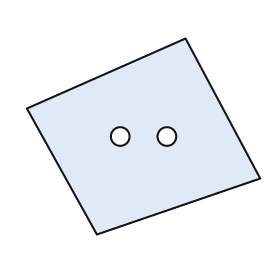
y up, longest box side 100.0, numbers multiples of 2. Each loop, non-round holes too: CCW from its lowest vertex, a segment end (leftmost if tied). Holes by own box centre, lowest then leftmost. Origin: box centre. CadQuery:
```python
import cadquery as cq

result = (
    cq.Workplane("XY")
    .moveTo(-20.0, -42.0)
    .lineTo(50.0, -18.0)
    .lineTo(18.0, 42.0)
    .lineTo(-50.0, 12.0)
    .close()
    .moveTo(-10.0, 0.0)
    .circle(4.0)
    .moveTo(10.0, 0.0)
    .circle(4.0)
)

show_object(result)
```